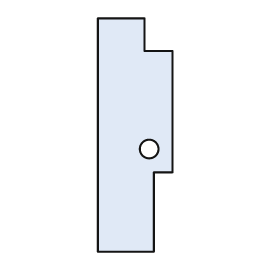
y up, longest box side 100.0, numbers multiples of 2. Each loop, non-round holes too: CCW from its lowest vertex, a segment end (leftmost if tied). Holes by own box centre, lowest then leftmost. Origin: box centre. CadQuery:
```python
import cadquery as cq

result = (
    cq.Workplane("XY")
    .moveTo(-16.0, -50.0)
    .lineTo(8.0, -50.0)
    .lineTo(8.0, -16.0)
    .lineTo(16.0, -16.0)
    .lineTo(16.0, 36.0)
    .lineTo(4.0, 36.0)
    .lineTo(4.0, 50.0)
    .lineTo(-16.0, 50.0)
    .close()
    .moveTo(6.0, -6.0)
    .circle(4.0)
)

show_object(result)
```